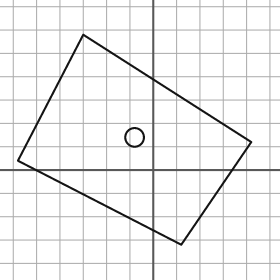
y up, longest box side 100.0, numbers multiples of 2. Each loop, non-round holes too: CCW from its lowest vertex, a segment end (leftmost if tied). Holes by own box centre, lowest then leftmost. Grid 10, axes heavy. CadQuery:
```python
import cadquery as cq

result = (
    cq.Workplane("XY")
    .moveTo(12.0, -32.0)
    .lineTo(42.0, 12.0)
    .lineTo(-30.0, 58.0)
    .lineTo(-58.0, 4.0)
    .close()
    .moveTo(-8.0, 14.0)
    .circle(4.0)
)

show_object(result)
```